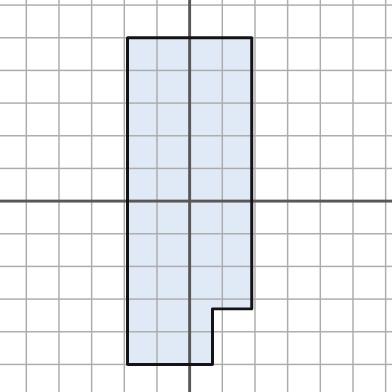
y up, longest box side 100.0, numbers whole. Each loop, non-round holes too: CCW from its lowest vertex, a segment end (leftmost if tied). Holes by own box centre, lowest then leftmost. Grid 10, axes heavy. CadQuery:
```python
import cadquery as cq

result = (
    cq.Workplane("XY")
    .moveTo(-19.0, -50.0)
    .lineTo(7.0, -50.0)
    .lineTo(7.0, -33.0)
    .lineTo(19.0, -33.0)
    .lineTo(19.0, 50.0)
    .lineTo(-19.0, 50.0)
    .close()
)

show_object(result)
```